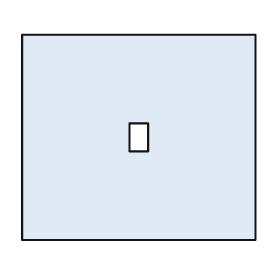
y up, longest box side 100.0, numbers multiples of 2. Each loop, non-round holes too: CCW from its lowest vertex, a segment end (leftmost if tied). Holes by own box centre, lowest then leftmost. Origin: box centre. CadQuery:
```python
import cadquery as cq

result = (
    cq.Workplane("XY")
    .moveTo(-50.0, -44.0)
    .lineTo(50.0, -44.0)
    .lineTo(50.0, 44.0)
    .lineTo(-50.0, 44.0)
    .close()
    .moveTo(-4.0, -6.0)
    .lineTo(4.0, -6.0)
    .lineTo(4.0, 6.0)
    .lineTo(-4.0, 6.0)
    .close()
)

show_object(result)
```